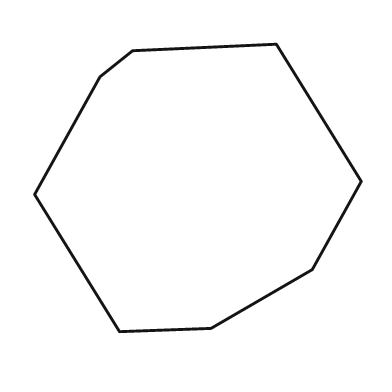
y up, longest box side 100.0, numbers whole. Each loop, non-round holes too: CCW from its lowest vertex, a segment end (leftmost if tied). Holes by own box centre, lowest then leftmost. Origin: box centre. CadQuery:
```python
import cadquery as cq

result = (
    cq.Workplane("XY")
    .moveTo(-24.0, -44.0)
    .lineTo(4.0, -43.0)
    .lineTo(35.0, -25.0)
    .lineTo(50.0, 2.0)
    .lineTo(24.0, 44.0)
    .lineTo(-20.0, 42.0)
    .lineTo(-30.0, 34.0)
    .lineTo(-50.0, -2.0)
    .close()
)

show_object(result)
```